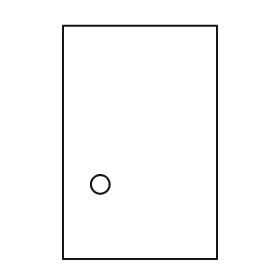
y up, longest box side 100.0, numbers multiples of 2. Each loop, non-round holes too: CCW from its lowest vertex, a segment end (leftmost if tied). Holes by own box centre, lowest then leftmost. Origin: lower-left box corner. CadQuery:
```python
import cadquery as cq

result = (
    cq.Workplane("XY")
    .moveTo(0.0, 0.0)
    .lineTo(66.0, 0.0)
    .lineTo(66.0, 100.0)
    .lineTo(0.0, 100.0)
    .close()
    .moveTo(16.0, 32.0)
    .circle(4.0)
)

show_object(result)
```